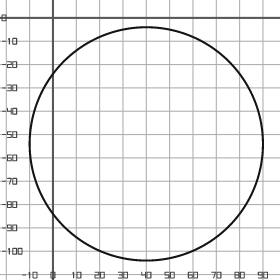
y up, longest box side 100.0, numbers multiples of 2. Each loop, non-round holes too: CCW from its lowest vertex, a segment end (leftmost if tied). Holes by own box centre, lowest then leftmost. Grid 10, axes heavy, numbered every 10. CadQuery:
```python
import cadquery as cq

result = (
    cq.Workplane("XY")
    .moveTo(40.0, -54.0)
    .circle(50.0)
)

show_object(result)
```